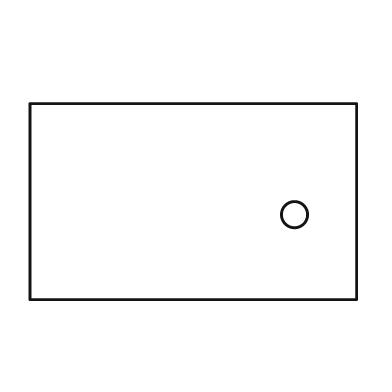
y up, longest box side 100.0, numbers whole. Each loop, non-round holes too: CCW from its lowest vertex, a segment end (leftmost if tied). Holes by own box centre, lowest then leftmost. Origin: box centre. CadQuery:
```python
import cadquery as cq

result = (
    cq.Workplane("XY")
    .moveTo(-50.0, -30.0)
    .lineTo(50.0, -30.0)
    .lineTo(50.0, 30.0)
    .lineTo(-50.0, 30.0)
    .close()
    .moveTo(31.0, -4.0)
    .circle(4.0)
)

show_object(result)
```